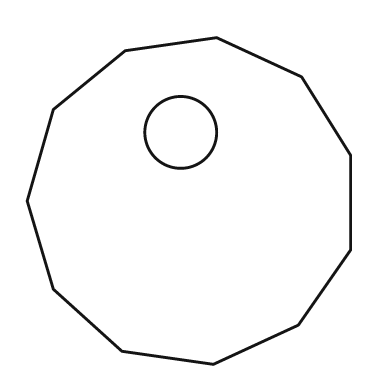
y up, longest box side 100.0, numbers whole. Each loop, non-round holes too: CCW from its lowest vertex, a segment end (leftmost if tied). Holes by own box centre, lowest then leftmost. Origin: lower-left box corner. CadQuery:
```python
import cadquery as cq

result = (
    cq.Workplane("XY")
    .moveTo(57.0, 0.0)
    .lineTo(83.0, 12.0)
    .lineTo(99.0, 35.0)
    .lineTo(99.0, 64.0)
    .lineTo(84.0, 88.0)
    .lineTo(58.0, 100.0)
    .lineTo(30.0, 96.0)
    .lineTo(8.0, 78.0)
    .lineTo(0.0, 50.0)
    .lineTo(8.0, 23.0)
    .lineTo(29.0, 4.0)
    .close()
    .moveTo(47.0, 71.0)
    .circle(11.0)
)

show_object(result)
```